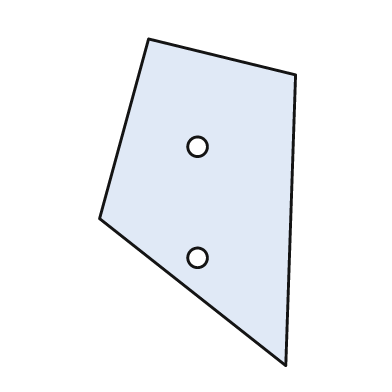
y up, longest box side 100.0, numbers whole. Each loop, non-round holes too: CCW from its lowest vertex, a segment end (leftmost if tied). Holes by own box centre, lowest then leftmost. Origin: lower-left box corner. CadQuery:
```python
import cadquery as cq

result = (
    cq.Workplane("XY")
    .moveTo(57.0, 0.0)
    .lineTo(60.0, 89.0)
    .lineTo(15.0, 100.0)
    .lineTo(0.0, 45.0)
    .close()
    .moveTo(30.0, 33.0)
    .circle(3.0)
    .moveTo(30.0, 67.0)
    .circle(3.0)
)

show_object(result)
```